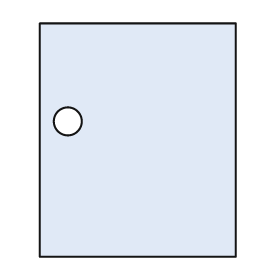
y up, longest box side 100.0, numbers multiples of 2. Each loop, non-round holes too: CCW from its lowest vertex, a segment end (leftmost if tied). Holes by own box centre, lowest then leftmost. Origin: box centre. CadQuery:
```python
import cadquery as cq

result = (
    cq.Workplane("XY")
    .moveTo(-42.0, -50.0)
    .lineTo(42.0, -50.0)
    .lineTo(42.0, 50.0)
    .lineTo(-42.0, 50.0)
    .close()
    .moveTo(-30.0, 8.0)
    .circle(6.0)
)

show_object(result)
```